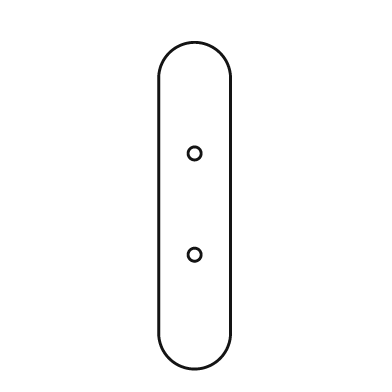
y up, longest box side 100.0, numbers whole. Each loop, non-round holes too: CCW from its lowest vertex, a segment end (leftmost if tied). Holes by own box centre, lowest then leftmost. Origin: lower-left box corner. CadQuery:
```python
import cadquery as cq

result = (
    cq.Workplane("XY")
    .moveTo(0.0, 11.0)
    .threePointArc((11.0, 0.0), (22.0, 11.0))
    .lineTo(22.0, 89.0)
    .threePointArc((11.0, 100.0), (0.0, 89.0))
    .close()
    .moveTo(11.0, 35.0)
    .circle(2.0)
    .moveTo(11.0, 66.0)
    .circle(2.0)
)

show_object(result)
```